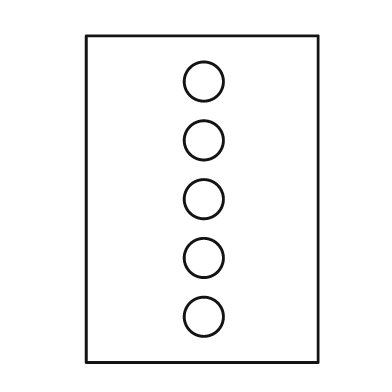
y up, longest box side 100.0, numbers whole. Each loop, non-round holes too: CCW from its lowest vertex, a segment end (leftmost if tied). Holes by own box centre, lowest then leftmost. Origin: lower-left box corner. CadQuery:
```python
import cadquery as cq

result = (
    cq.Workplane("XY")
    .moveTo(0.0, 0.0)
    .lineTo(71.0, 0.0)
    .lineTo(71.0, 100.0)
    .lineTo(0.0, 100.0)
    .close()
    .moveTo(36.0, 14.0)
    .circle(6.0)
    .moveTo(36.0, 32.0)
    .circle(6.0)
    .moveTo(36.0, 50.0)
    .circle(6.0)
    .moveTo(36.0, 68.0)
    .circle(6.0)
    .moveTo(36.0, 86.0)
    .circle(6.0)
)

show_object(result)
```